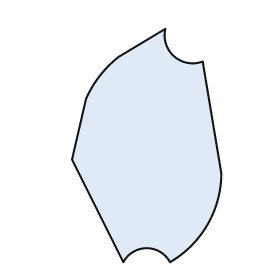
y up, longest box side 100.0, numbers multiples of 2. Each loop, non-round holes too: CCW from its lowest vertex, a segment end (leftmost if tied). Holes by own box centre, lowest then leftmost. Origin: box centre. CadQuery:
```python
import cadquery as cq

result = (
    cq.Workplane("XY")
    .moveTo(-10.0, -50.0)
    .threePointArc((0.0, -44.0), (10.0, -50.0))
    .threePointArc((26.0, -34.0), (32.0, -12.0))
    .lineTo(24.0, 36.0)
    .threePointArc((12.0, 38.0), (8.0, 50.0))
    .lineTo(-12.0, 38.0)
    .threePointArc((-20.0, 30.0), (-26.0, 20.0))
    .lineTo(-32.0, -6.0)
    .close()
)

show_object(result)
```